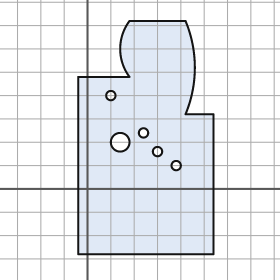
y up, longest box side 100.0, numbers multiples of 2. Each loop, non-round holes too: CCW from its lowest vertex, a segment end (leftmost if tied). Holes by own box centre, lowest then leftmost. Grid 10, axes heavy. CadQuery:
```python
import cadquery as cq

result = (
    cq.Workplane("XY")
    .moveTo(-4.0, -28.0)
    .lineTo(54.0, -28.0)
    .lineTo(54.0, 32.0)
    .lineTo(42.0, 32.0)
    .threePointArc((46.0, 52.0), (42.0, 72.0))
    .lineTo(18.0, 72.0)
    .threePointArc((14.0, 60.0), (18.0, 48.0))
    .lineTo(-4.0, 48.0)
    .close()
    .moveTo(38.0, 10.0)
    .circle(2.0)
    .moveTo(30.0, 16.0)
    .circle(2.0)
    .moveTo(14.0, 20.0)
    .circle(4.0)
    .moveTo(24.0, 24.0)
    .circle(2.0)
    .moveTo(10.0, 40.0)
    .circle(2.0)
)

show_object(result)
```